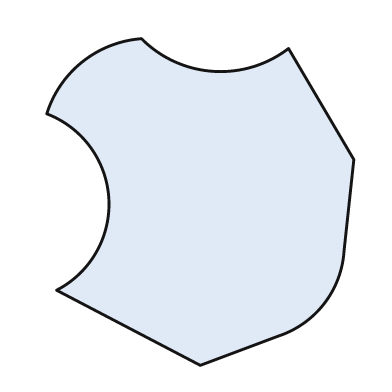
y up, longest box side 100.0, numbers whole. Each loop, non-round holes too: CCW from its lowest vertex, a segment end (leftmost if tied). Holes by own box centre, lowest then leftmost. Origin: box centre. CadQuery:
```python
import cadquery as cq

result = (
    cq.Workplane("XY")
    .moveTo(0.0, -50.0)
    .lineTo(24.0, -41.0)
    .threePointArc((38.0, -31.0), (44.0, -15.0))
    .lineTo(47.0, 13.0)
    .lineTo(27.0, 47.0)
    .threePointArc((4.0, 40.0), (-18.0, 50.0))
    .threePointArc((-36.0, 43.0), (-47.0, 27.0))
    .threePointArc((-28.0, 1.0), (-44.0, -27.0))
    .close()
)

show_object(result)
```